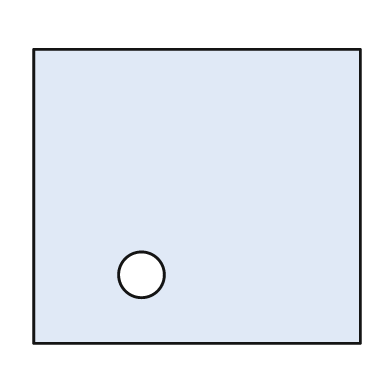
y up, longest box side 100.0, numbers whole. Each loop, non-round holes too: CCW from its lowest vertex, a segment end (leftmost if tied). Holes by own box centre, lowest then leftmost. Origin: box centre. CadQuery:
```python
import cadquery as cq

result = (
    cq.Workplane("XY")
    .moveTo(-50.0, -45.0)
    .lineTo(50.0, -45.0)
    .lineTo(50.0, 45.0)
    .lineTo(-50.0, 45.0)
    .close()
    .moveTo(-17.0, -24.0)
    .circle(7.0)
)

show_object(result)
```